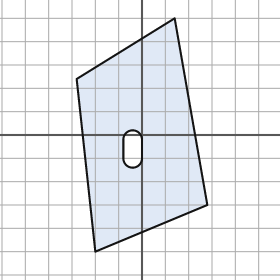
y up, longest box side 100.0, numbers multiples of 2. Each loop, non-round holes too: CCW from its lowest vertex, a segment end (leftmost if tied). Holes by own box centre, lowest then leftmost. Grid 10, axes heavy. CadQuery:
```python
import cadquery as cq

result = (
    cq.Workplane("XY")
    .moveTo(-20.0, -50.0)
    .lineTo(28.0, -30.0)
    .lineTo(14.0, 50.0)
    .lineTo(-28.0, 24.0)
    .close()
    .moveTo(-8.0, -10.0)
    .threePointArc((-4.0, -14.0), (0.0, -10.0))
    .lineTo(0.0, -2.0)
    .threePointArc((-4.0, 2.0), (-8.0, -2.0))
    .close()
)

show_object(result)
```